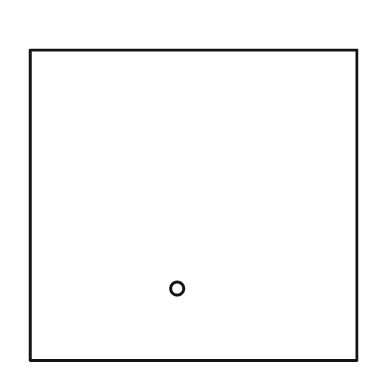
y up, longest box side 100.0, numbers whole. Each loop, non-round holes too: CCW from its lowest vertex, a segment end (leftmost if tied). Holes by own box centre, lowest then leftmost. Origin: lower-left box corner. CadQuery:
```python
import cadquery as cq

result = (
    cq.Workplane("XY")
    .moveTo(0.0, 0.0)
    .lineTo(100.0, 0.0)
    .lineTo(100.0, 95.0)
    .lineTo(0.0, 95.0)
    .close()
    .moveTo(45.0, 22.0)
    .circle(2.0)
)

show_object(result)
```